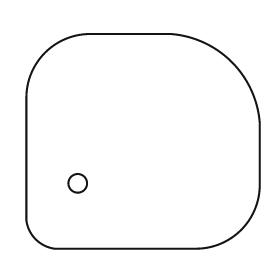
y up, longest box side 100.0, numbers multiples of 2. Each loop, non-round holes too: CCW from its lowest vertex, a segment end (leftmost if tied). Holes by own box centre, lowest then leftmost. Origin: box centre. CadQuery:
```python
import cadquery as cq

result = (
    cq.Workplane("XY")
    .moveTo(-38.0, -46.0)
    .lineTo(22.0, -46.0)
    .threePointArc((42.0, -38.0), (50.0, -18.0))
    .lineTo(50.0, 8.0)
    .threePointArc((38.0, 34.0), (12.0, 46.0))
    .lineTo(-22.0, 46.0)
    .threePointArc((-42.0, 38.0), (-50.0, 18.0))
    .lineTo(-50.0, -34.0)
    .threePointArc((-46.0, -42.0), (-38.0, -46.0))
    .close()
    .moveTo(-28.0, -18.0)
    .circle(4.0)
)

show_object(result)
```